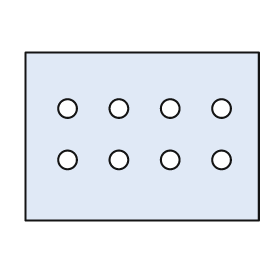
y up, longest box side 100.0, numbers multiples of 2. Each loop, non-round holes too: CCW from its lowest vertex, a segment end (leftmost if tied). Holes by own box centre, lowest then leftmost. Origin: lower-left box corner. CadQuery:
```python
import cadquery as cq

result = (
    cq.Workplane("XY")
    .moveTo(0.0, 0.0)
    .lineTo(100.0, 0.0)
    .lineTo(100.0, 72.0)
    .lineTo(0.0, 72.0)
    .close()
    .moveTo(18.0, 26.0)
    .circle(4.0)
    .moveTo(40.0, 26.0)
    .circle(4.0)
    .moveTo(62.0, 26.0)
    .circle(4.0)
    .moveTo(84.0, 26.0)
    .circle(4.0)
    .moveTo(18.0, 48.0)
    .circle(4.0)
    .moveTo(40.0, 48.0)
    .circle(4.0)
    .moveTo(62.0, 48.0)
    .circle(4.0)
    .moveTo(84.0, 48.0)
    .circle(4.0)
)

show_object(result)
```